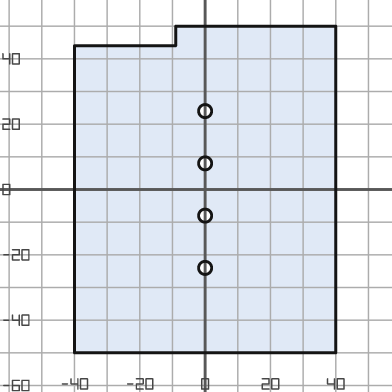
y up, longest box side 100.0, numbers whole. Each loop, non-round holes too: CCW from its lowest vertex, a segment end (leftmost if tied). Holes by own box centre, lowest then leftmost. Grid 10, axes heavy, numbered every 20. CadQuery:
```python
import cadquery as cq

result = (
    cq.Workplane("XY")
    .moveTo(-40.0, -50.0)
    .lineTo(40.0, -50.0)
    .lineTo(40.0, 50.0)
    .lineTo(-9.0, 50.0)
    .lineTo(-9.0, 44.0)
    .lineTo(-40.0, 44.0)
    .close()
    .moveTo(0.0, -24.0)
    .circle(2.0)
    .moveTo(0.0, -8.0)
    .circle(2.0)
    .moveTo(0.0, 8.0)
    .circle(2.0)
    .moveTo(0.0, 24.0)
    .circle(2.0)
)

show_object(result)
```